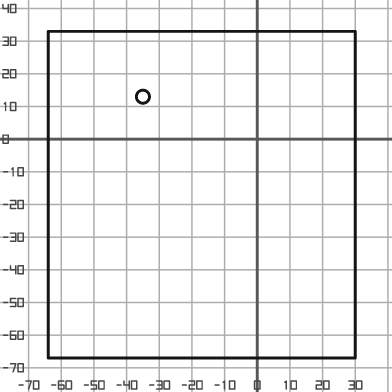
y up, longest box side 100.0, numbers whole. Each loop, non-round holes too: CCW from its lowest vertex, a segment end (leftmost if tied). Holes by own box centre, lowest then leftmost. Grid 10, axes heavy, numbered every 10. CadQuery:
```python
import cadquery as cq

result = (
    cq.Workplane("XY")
    .moveTo(-64.0, -67.0)
    .lineTo(30.0, -67.0)
    .lineTo(30.0, 33.0)
    .lineTo(-64.0, 33.0)
    .close()
    .moveTo(-35.0, 13.0)
    .circle(2.0)
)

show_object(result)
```